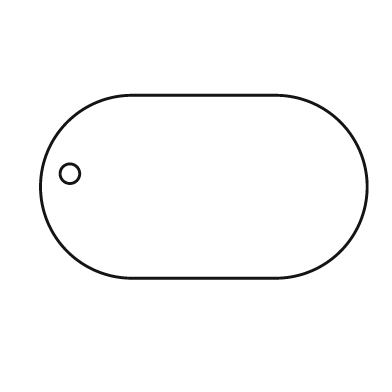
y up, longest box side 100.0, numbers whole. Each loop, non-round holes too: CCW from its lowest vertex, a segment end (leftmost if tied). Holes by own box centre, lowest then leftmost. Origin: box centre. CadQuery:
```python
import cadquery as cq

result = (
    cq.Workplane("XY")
    .moveTo(-22.0, -28.0)
    .lineTo(22.0, -28.0)
    .threePointArc((50.0, 0.0), (22.0, 28.0))
    .lineTo(-22.0, 28.0)
    .threePointArc((-50.0, 0.0), (-22.0, -28.0))
    .close()
    .moveTo(-41.0, 4.0)
    .circle(3.0)
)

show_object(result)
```